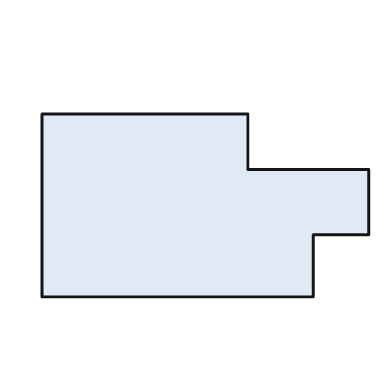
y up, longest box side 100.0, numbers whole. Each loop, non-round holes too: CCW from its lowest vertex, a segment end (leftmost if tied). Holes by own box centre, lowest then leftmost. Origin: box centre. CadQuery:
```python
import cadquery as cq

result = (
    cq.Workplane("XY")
    .moveTo(-50.0, -28.0)
    .lineTo(33.0, -28.0)
    .lineTo(33.0, -9.0)
    .lineTo(50.0, -9.0)
    .lineTo(50.0, 11.0)
    .lineTo(13.0, 11.0)
    .lineTo(13.0, 28.0)
    .lineTo(-50.0, 28.0)
    .close()
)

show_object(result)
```